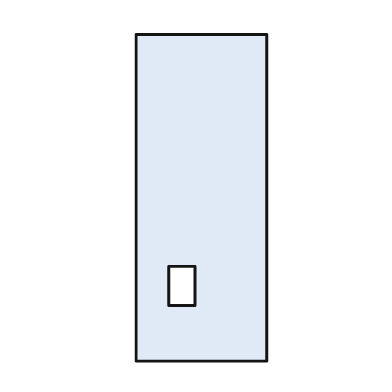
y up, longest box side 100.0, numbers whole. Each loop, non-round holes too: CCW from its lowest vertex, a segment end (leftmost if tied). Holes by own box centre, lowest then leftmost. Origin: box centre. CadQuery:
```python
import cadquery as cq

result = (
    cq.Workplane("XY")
    .moveTo(-20.0, -50.0)
    .lineTo(20.0, -50.0)
    .lineTo(20.0, 50.0)
    .lineTo(-20.0, 50.0)
    .close()
    .moveTo(-10.0, -33.0)
    .lineTo(-2.0, -33.0)
    .lineTo(-2.0, -21.0)
    .lineTo(-10.0, -21.0)
    .close()
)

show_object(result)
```